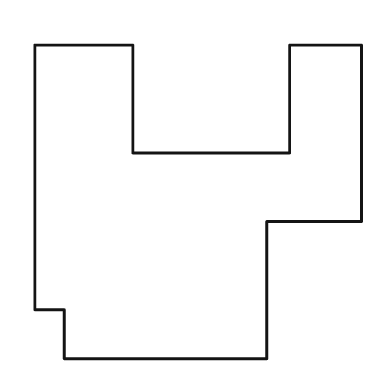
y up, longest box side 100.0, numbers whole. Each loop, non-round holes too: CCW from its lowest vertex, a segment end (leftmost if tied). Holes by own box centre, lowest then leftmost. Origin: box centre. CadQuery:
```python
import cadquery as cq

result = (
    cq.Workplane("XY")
    .moveTo(-41.0, -48.0)
    .lineTo(21.0, -48.0)
    .lineTo(21.0, -6.0)
    .lineTo(50.0, -6.0)
    .lineTo(50.0, 48.0)
    .lineTo(28.0, 48.0)
    .lineTo(28.0, 15.0)
    .lineTo(-20.0, 15.0)
    .lineTo(-20.0, 48.0)
    .lineTo(-50.0, 48.0)
    .lineTo(-50.0, -33.0)
    .lineTo(-41.0, -33.0)
    .close()
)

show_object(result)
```